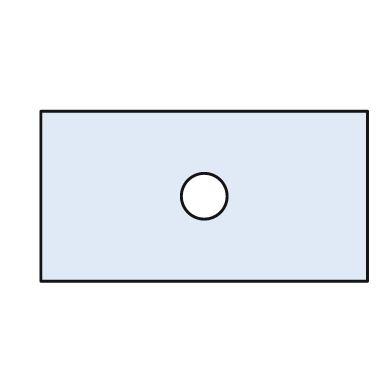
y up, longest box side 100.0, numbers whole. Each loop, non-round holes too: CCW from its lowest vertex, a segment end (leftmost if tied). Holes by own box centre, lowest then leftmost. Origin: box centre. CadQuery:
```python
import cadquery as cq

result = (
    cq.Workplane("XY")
    .moveTo(-50.0, -26.0)
    .lineTo(50.0, -26.0)
    .lineTo(50.0, 26.0)
    .lineTo(-50.0, 26.0)
    .close()
    .moveTo(0.0, 0.0)
    .circle(7.0)
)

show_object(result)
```